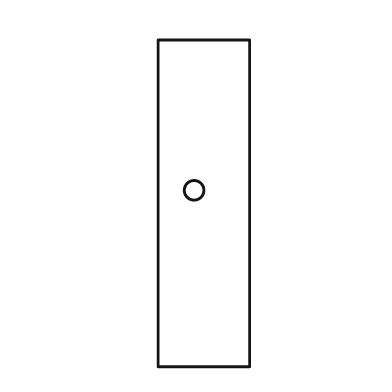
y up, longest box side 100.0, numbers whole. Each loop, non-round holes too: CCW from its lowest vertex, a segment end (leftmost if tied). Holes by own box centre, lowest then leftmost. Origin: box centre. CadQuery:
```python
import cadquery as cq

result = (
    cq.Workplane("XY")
    .moveTo(-14.0, -50.0)
    .lineTo(14.0, -50.0)
    .lineTo(14.0, 50.0)
    .lineTo(-14.0, 50.0)
    .close()
    .moveTo(-3.0, 4.0)
    .circle(3.0)
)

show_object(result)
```